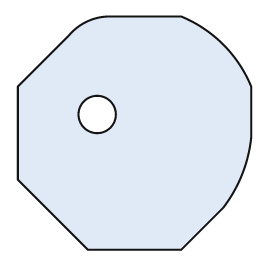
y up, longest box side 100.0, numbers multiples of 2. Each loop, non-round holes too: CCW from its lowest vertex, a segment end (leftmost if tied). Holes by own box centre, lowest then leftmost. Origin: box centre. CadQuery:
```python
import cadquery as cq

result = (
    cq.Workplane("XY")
    .moveTo(-20.0, -50.0)
    .lineTo(20.0, -50.0)
    .lineTo(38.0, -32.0)
    .threePointArc((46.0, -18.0), (50.0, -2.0))
    .lineTo(50.0, 20.0)
    .threePointArc((38.0, 38.0), (20.0, 50.0))
    .lineTo(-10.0, 50.0)
    .threePointArc((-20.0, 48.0), (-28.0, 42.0))
    .lineTo(-50.0, 20.0)
    .lineTo(-50.0, -20.0)
    .close()
    .moveTo(-16.0, 8.0)
    .circle(8.0)
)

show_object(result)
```